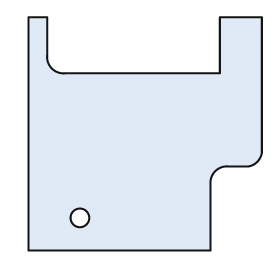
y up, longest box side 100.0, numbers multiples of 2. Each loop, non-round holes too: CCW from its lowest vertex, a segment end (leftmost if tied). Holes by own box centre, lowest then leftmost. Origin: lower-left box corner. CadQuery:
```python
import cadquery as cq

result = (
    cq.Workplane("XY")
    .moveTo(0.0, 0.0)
    .lineTo(78.0, 0.0)
    .lineTo(78.0, 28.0)
    .threePointArc((80.0, 34.0), (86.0, 36.0))
    .lineTo(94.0, 36.0)
    .threePointArc((98.0, 38.0), (100.0, 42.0))
    .lineTo(100.0, 100.0)
    .lineTo(82.0, 100.0)
    .lineTo(82.0, 76.0)
    .lineTo(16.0, 76.0)
    .threePointArc((10.0, 78.0), (8.0, 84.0))
    .lineTo(8.0, 100.0)
    .lineTo(0.0, 100.0)
    .close()
    .moveTo(22.0, 14.0)
    .circle(4.0)
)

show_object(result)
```